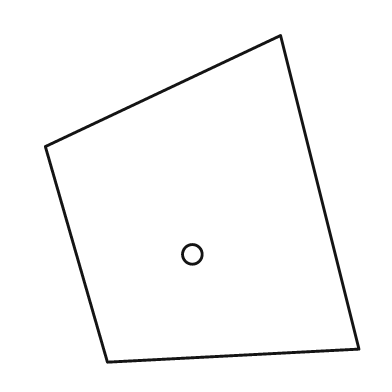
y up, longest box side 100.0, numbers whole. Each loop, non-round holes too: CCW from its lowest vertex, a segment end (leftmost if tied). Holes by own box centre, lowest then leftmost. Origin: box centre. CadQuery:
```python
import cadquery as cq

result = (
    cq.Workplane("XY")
    .moveTo(-29.0, -50.0)
    .lineTo(48.0, -46.0)
    .lineTo(24.0, 50.0)
    .lineTo(-48.0, 16.0)
    .close()
    .moveTo(-3.0, -17.0)
    .circle(3.0)
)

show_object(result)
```